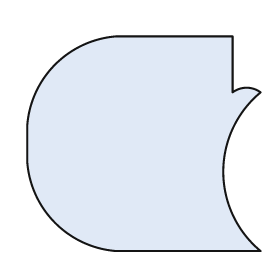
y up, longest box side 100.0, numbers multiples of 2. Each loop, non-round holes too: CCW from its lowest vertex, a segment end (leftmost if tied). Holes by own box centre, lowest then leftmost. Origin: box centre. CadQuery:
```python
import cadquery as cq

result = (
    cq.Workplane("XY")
    .moveTo(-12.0, -46.0)
    .lineTo(50.0, -46.0)
    .threePointArc((34.0, -12.0), (50.0, 22.0))
    .threePointArc((44.0, 24.0), (38.0, 22.0))
    .lineTo(38.0, 46.0)
    .lineTo(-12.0, 46.0)
    .threePointArc((-38.0, 34.0), (-50.0, 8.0))
    .lineTo(-50.0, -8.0)
    .threePointArc((-38.0, -34.0), (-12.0, -46.0))
    .close()
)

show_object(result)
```